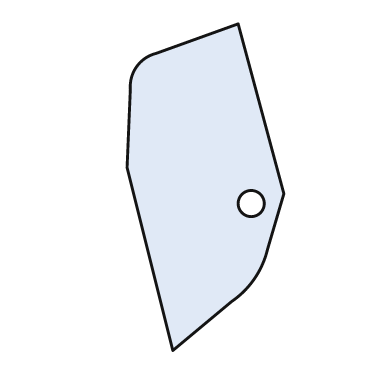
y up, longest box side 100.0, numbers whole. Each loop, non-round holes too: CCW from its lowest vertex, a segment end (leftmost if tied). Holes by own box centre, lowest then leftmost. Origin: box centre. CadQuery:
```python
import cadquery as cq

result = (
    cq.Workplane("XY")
    .moveTo(-10.0, -50.0)
    .lineTo(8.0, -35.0)
    .threePointArc((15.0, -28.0), (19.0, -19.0))
    .lineTo(24.0, -2.0)
    .lineTo(10.0, 50.0)
    .lineTo(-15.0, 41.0)
    .threePointArc((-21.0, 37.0), (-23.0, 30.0))
    .lineTo(-24.0, 6.0)
    .close()
    .moveTo(14.0, -5.0)
    .circle(4.0)
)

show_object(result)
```